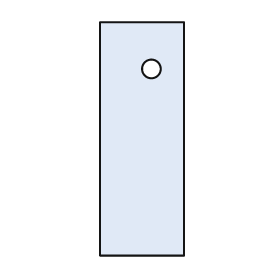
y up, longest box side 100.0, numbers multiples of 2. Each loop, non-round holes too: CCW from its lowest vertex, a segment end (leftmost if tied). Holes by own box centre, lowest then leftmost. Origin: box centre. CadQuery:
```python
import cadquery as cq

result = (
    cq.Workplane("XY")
    .moveTo(-18.0, -50.0)
    .lineTo(18.0, -50.0)
    .lineTo(18.0, 50.0)
    .lineTo(-18.0, 50.0)
    .close()
    .moveTo(4.0, 30.0)
    .circle(4.0)
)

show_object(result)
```